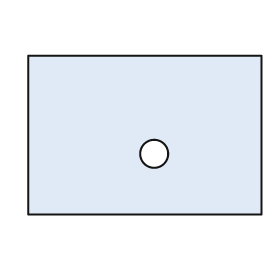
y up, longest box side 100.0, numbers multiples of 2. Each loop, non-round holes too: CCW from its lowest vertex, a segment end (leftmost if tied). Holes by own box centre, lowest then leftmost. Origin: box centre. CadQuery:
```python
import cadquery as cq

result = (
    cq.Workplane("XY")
    .moveTo(-50.0, -34.0)
    .lineTo(50.0, -34.0)
    .lineTo(50.0, 34.0)
    .lineTo(-50.0, 34.0)
    .close()
    .moveTo(4.0, -8.0)
    .circle(6.0)
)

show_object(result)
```